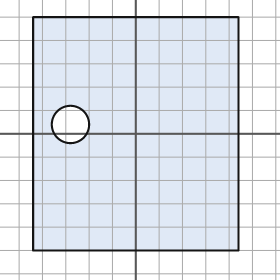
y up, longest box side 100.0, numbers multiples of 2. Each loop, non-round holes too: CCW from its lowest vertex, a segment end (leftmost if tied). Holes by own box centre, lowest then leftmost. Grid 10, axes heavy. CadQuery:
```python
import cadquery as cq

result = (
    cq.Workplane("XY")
    .moveTo(-44.0, -50.0)
    .lineTo(44.0, -50.0)
    .lineTo(44.0, 50.0)
    .lineTo(-44.0, 50.0)
    .close()
    .moveTo(-28.0, 4.0)
    .circle(8.0)
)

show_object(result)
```